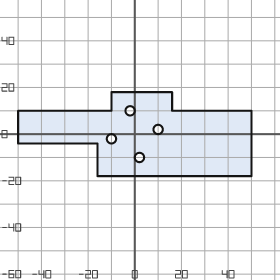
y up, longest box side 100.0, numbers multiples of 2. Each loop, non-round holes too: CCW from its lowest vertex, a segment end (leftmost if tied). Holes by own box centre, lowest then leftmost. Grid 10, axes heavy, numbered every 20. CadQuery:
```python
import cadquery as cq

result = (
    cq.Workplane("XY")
    .moveTo(-16.0, -18.0)
    .lineTo(50.0, -18.0)
    .lineTo(50.0, 10.0)
    .lineTo(16.0, 10.0)
    .lineTo(16.0, 18.0)
    .lineTo(-10.0, 18.0)
    .lineTo(-10.0, 10.0)
    .lineTo(-50.0, 10.0)
    .lineTo(-50.0, -4.0)
    .lineTo(-16.0, -4.0)
    .close()
    .moveTo(2.0, -10.0)
    .circle(2.0)
    .moveTo(-10.0, -2.0)
    .circle(2.0)
    .moveTo(10.0, 2.0)
    .circle(2.0)
    .moveTo(-2.0, 10.0)
    .circle(2.0)
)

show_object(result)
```